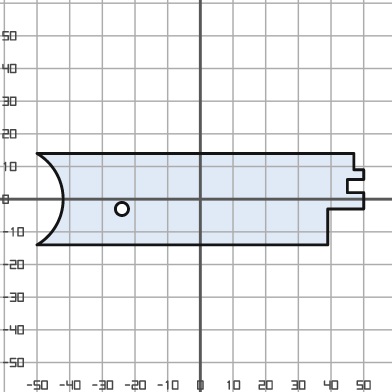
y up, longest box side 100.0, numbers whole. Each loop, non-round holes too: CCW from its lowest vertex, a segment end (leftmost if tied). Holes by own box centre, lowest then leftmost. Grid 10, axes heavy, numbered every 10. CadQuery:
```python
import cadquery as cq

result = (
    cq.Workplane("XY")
    .moveTo(-50.0, -14.0)
    .lineTo(39.0, -14.0)
    .lineTo(39.0, -3.0)
    .lineTo(50.0, -3.0)
    .lineTo(50.0, 2.0)
    .lineTo(45.0, 2.0)
    .lineTo(45.0, 6.0)
    .lineTo(50.0, 6.0)
    .lineTo(50.0, 9.0)
    .lineTo(47.0, 9.0)
    .lineTo(47.0, 14.0)
    .lineTo(-50.0, 14.0)
    .threePointArc((-42.0, 0.0), (-50.0, -14.0))
    .close()
    .moveTo(-24.0, -3.0)
    .circle(2.0)
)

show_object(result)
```